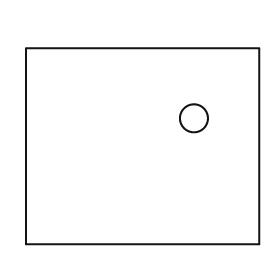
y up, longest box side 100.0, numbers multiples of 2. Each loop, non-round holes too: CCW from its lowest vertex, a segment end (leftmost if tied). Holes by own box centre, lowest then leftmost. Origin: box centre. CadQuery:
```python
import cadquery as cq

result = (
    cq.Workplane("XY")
    .moveTo(-50.0, -42.0)
    .lineTo(50.0, -42.0)
    .lineTo(50.0, 42.0)
    .lineTo(-50.0, 42.0)
    .close()
    .moveTo(22.0, 12.0)
    .circle(6.0)
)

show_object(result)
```